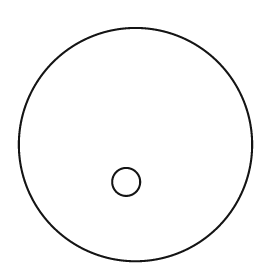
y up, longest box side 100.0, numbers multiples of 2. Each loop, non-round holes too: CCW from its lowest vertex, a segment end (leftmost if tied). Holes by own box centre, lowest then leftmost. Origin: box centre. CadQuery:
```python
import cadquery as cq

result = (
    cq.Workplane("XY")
    .moveTo(0.0, 0.0)
    .circle(50.0)
    .moveTo(-4.0, -16.0)
    .circle(6.0)
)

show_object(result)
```